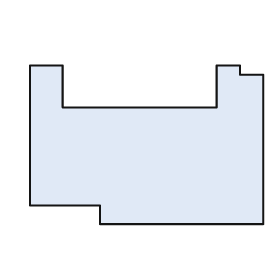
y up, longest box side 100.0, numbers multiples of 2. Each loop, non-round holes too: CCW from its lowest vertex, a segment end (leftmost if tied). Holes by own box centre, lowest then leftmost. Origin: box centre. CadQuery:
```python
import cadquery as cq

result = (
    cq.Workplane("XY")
    .moveTo(-20.0, -34.0)
    .lineTo(50.0, -34.0)
    .lineTo(50.0, 30.0)
    .lineTo(40.0, 30.0)
    .lineTo(40.0, 34.0)
    .lineTo(30.0, 34.0)
    .lineTo(30.0, 16.0)
    .lineTo(-36.0, 16.0)
    .lineTo(-36.0, 34.0)
    .lineTo(-50.0, 34.0)
    .lineTo(-50.0, -26.0)
    .lineTo(-20.0, -26.0)
    .close()
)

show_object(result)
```